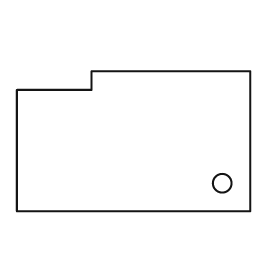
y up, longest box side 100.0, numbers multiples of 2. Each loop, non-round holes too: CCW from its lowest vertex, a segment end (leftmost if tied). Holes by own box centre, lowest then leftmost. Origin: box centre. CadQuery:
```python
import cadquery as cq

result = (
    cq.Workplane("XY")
    .moveTo(-50.0, -30.0)
    .lineTo(50.0, -30.0)
    .lineTo(50.0, 30.0)
    .lineTo(-18.0, 30.0)
    .lineTo(-18.0, 22.0)
    .lineTo(-50.0, 22.0)
    .close()
    .moveTo(38.0, -18.0)
    .circle(4.0)
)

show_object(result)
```